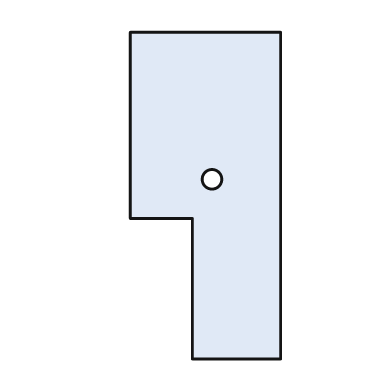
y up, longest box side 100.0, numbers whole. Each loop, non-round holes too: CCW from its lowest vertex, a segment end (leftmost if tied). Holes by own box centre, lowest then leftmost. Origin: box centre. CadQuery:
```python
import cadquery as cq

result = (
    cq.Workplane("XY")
    .moveTo(-4.0, -50.0)
    .lineTo(23.0, -50.0)
    .lineTo(23.0, 50.0)
    .lineTo(-23.0, 50.0)
    .lineTo(-23.0, -7.0)
    .lineTo(-4.0, -7.0)
    .close()
    .moveTo(2.0, 5.0)
    .circle(3.0)
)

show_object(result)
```